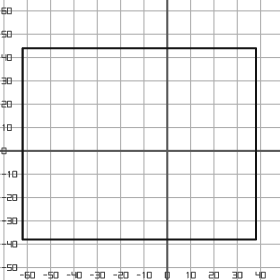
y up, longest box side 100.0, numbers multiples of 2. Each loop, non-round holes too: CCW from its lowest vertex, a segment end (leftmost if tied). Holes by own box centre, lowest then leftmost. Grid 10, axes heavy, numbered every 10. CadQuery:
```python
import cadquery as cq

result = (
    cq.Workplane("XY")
    .moveTo(-62.0, -38.0)
    .lineTo(38.0, -38.0)
    .lineTo(38.0, 44.0)
    .lineTo(-62.0, 44.0)
    .close()
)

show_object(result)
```